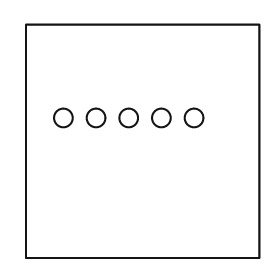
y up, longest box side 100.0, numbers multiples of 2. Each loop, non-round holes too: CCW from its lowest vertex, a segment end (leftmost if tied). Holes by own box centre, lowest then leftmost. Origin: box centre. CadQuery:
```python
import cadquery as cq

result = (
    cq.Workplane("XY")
    .moveTo(-50.0, -50.0)
    .lineTo(50.0, -50.0)
    .lineTo(50.0, 50.0)
    .lineTo(-50.0, 50.0)
    .close()
    .moveTo(-34.0, 10.0)
    .circle(4.0)
    .moveTo(-20.0, 10.0)
    .circle(4.0)
    .moveTo(-6.0, 10.0)
    .circle(4.0)
    .moveTo(8.0, 10.0)
    .circle(4.0)
    .moveTo(22.0, 10.0)
    .circle(4.0)
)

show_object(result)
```